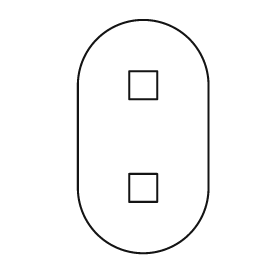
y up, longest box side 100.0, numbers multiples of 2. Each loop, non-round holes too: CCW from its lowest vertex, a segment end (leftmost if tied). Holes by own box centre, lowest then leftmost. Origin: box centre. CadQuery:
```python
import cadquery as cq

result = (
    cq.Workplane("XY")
    .moveTo(-28.0, -22.0)
    .threePointArc((0.0, -50.0), (28.0, -22.0))
    .lineTo(28.0, 22.0)
    .threePointArc((0.0, 50.0), (-28.0, 22.0))
    .close()
    .moveTo(-6.0, -28.0)
    .lineTo(6.0, -28.0)
    .lineTo(6.0, -16.0)
    .lineTo(-6.0, -16.0)
    .close()
    .moveTo(-6.0, 16.0)
    .lineTo(6.0, 16.0)
    .lineTo(6.0, 28.0)
    .lineTo(-6.0, 28.0)
    .close()
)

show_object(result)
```